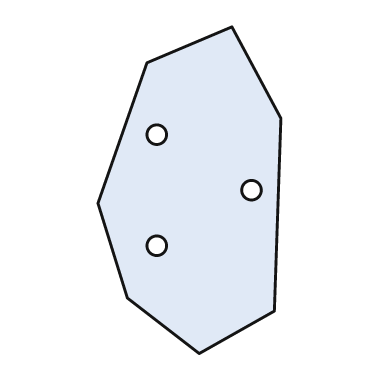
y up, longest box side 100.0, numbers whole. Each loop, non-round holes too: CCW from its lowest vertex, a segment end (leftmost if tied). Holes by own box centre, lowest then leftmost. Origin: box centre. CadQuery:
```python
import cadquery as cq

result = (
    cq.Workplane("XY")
    .moveTo(3.0, -50.0)
    .lineTo(26.0, -37.0)
    .lineTo(28.0, 22.0)
    .lineTo(13.0, 50.0)
    .lineTo(-13.0, 39.0)
    .lineTo(-28.0, -4.0)
    .lineTo(-19.0, -33.0)
    .close()
    .moveTo(-10.0, -17.0)
    .circle(3.0)
    .moveTo(19.0, 0.0)
    .circle(3.0)
    .moveTo(-10.0, 17.0)
    .circle(3.0)
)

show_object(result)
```